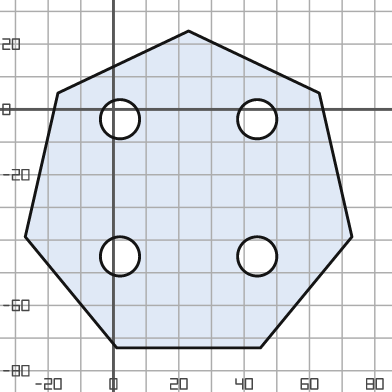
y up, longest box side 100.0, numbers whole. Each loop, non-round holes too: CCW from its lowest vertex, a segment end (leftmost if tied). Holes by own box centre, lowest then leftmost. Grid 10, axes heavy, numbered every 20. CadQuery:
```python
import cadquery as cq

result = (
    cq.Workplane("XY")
    .moveTo(1.0, -73.0)
    .lineTo(45.0, -73.0)
    .lineTo(73.0, -39.0)
    .lineTo(63.0, 5.0)
    .lineTo(23.0, 24.0)
    .lineTo(-17.0, 5.0)
    .lineTo(-27.0, -39.0)
    .close()
    .moveTo(2.0, -45.0)
    .circle(6.0)
    .moveTo(44.0, -45.0)
    .circle(6.0)
    .moveTo(2.0, -3.0)
    .circle(6.0)
    .moveTo(44.0, -3.0)
    .circle(6.0)
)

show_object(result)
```